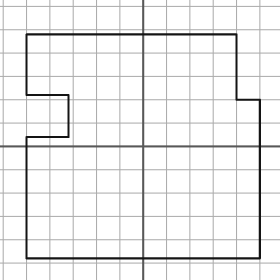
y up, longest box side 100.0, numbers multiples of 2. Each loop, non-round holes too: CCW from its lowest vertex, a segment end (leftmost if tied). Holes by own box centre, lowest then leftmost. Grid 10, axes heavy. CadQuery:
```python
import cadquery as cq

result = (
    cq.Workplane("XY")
    .moveTo(-50.0, -48.0)
    .lineTo(50.0, -48.0)
    .lineTo(50.0, 20.0)
    .lineTo(40.0, 20.0)
    .lineTo(40.0, 48.0)
    .lineTo(-50.0, 48.0)
    .lineTo(-50.0, 22.0)
    .lineTo(-32.0, 22.0)
    .lineTo(-32.0, 4.0)
    .lineTo(-50.0, 4.0)
    .close()
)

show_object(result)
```